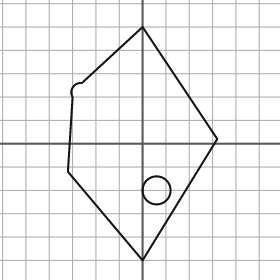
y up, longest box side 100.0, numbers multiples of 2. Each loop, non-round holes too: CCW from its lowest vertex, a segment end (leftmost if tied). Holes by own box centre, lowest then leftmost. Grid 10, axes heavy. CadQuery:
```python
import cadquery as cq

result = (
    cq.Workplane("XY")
    .moveTo(0.0, -50.0)
    .lineTo(32.0, 2.0)
    .lineTo(0.0, 50.0)
    .lineTo(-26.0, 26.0)
    .threePointArc((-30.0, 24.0), (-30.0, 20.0))
    .lineTo(-32.0, -12.0)
    .close()
    .moveTo(6.0, -20.0)
    .circle(6.0)
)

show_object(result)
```